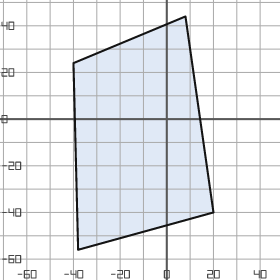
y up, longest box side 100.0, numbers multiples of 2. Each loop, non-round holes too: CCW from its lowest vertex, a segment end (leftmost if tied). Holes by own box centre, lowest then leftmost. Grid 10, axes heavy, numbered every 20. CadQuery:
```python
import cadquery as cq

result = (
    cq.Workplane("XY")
    .moveTo(-38.0, -56.0)
    .lineTo(20.0, -40.0)
    .lineTo(8.0, 44.0)
    .lineTo(-40.0, 24.0)
    .close()
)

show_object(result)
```